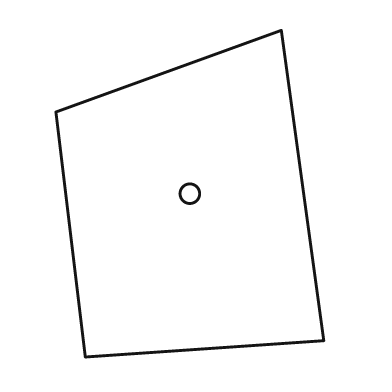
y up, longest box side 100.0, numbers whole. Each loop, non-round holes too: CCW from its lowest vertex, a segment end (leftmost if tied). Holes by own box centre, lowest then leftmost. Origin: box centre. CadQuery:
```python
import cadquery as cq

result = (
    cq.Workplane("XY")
    .moveTo(-32.0, -50.0)
    .lineTo(41.0, -45.0)
    .lineTo(28.0, 50.0)
    .lineTo(-41.0, 25.0)
    .close()
    .moveTo(0.0, 0.0)
    .circle(3.0)
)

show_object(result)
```